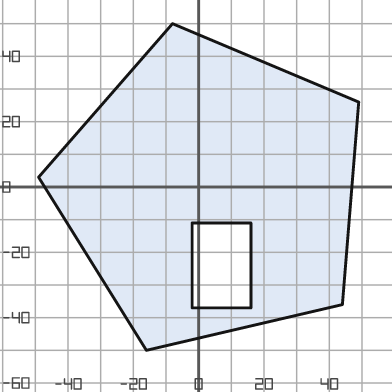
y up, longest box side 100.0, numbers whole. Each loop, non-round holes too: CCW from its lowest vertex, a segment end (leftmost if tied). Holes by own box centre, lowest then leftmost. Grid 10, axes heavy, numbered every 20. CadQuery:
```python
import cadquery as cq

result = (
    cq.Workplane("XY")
    .moveTo(-16.0, -50.0)
    .lineTo(44.0, -36.0)
    .lineTo(49.0, 26.0)
    .lineTo(-8.0, 50.0)
    .lineTo(-49.0, 3.0)
    .close()
    .moveTo(-2.0, -37.0)
    .lineTo(16.0, -37.0)
    .lineTo(16.0, -11.0)
    .lineTo(-2.0, -11.0)
    .close()
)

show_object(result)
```